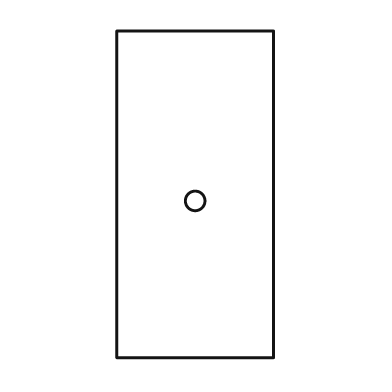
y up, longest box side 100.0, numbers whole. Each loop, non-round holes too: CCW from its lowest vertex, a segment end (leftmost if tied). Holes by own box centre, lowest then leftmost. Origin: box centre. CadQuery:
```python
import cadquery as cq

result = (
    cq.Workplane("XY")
    .moveTo(-24.0, -50.0)
    .lineTo(24.0, -50.0)
    .lineTo(24.0, 50.0)
    .lineTo(-24.0, 50.0)
    .close()
    .moveTo(0.0, -2.0)
    .circle(3.0)
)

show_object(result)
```